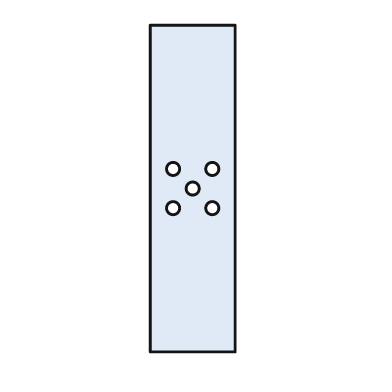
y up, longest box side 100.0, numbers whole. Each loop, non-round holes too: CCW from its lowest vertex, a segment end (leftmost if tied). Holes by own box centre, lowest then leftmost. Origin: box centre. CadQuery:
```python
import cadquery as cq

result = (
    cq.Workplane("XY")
    .moveTo(-13.0, -50.0)
    .lineTo(13.0, -50.0)
    .lineTo(13.0, 50.0)
    .lineTo(-13.0, 50.0)
    .close()
    .moveTo(-6.0, -6.0)
    .circle(2.0)
    .moveTo(6.0, -6.0)
    .circle(2.0)
    .moveTo(0.0, 0.0)
    .circle(2.0)
    .moveTo(-6.0, 6.0)
    .circle(2.0)
    .moveTo(6.0, 6.0)
    .circle(2.0)
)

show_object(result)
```